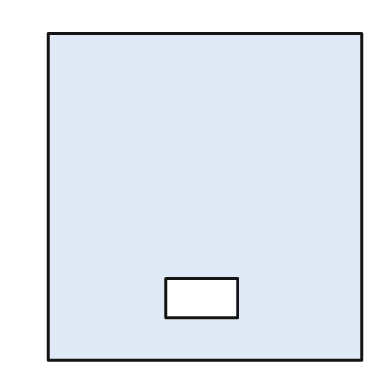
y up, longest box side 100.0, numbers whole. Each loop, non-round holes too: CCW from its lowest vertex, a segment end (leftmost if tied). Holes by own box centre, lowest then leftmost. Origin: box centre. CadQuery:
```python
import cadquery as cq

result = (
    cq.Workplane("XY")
    .moveTo(-48.0, -50.0)
    .lineTo(48.0, -50.0)
    .lineTo(48.0, 50.0)
    .lineTo(-48.0, 50.0)
    .close()
    .moveTo(-12.0, -37.0)
    .lineTo(10.0, -37.0)
    .lineTo(10.0, -25.0)
    .lineTo(-12.0, -25.0)
    .close()
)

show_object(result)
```